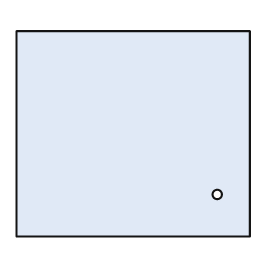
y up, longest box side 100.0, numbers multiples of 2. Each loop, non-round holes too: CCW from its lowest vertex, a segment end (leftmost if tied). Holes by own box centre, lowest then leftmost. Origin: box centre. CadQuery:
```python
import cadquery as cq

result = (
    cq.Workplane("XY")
    .moveTo(-50.0, -44.0)
    .lineTo(50.0, -44.0)
    .lineTo(50.0, 44.0)
    .lineTo(-50.0, 44.0)
    .close()
    .moveTo(36.0, -26.0)
    .circle(2.0)
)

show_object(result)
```